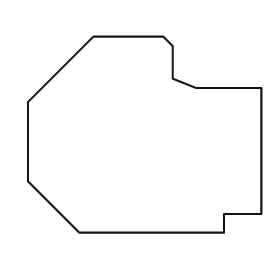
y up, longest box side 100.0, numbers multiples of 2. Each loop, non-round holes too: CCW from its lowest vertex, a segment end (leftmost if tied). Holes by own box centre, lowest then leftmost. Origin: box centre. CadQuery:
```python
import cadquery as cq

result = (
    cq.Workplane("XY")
    .moveTo(-28.0, -42.0)
    .lineTo(34.0, -42.0)
    .lineTo(34.0, -34.0)
    .lineTo(50.0, -34.0)
    .lineTo(50.0, 20.0)
    .lineTo(22.0, 20.0)
    .lineTo(12.0, 24.0)
    .lineTo(12.0, 38.0)
    .lineTo(8.0, 42.0)
    .lineTo(-22.0, 42.0)
    .lineTo(-50.0, 14.0)
    .lineTo(-50.0, -20.0)
    .close()
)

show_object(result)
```